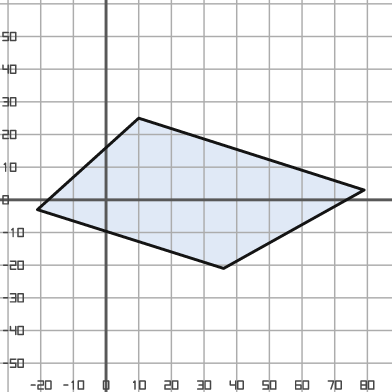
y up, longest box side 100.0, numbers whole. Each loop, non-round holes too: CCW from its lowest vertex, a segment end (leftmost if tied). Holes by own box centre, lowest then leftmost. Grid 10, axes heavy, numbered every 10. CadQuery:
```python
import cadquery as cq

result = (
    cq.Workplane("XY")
    .moveTo(36.0, -21.0)
    .lineTo(79.0, 3.0)
    .lineTo(10.0, 25.0)
    .lineTo(-21.0, -3.0)
    .close()
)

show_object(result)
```